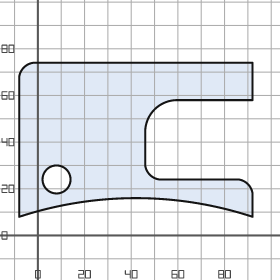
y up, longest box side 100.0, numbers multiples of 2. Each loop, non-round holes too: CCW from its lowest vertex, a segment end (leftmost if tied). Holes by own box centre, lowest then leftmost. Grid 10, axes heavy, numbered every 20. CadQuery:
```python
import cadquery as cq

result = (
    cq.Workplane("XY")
    .moveTo(-8.0, 8.0)
    .threePointArc((42.0, 16.0), (92.0, 8.0))
    .lineTo(92.0, 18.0)
    .threePointArc((90.0, 22.0), (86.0, 24.0))
    .lineTo(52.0, 24.0)
    .threePointArc((48.0, 26.0), (46.0, 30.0))
    .lineTo(46.0, 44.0)
    .threePointArc((50.0, 54.0), (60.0, 58.0))
    .lineTo(92.0, 58.0)
    .lineTo(92.0, 74.0)
    .lineTo(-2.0, 74.0)
    .threePointArc((-6.0, 72.0), (-8.0, 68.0))
    .close()
    .moveTo(8.0, 24.0)
    .circle(6.0)
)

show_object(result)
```